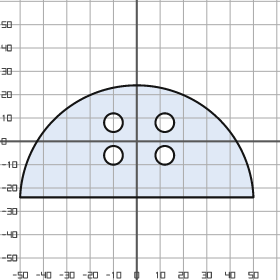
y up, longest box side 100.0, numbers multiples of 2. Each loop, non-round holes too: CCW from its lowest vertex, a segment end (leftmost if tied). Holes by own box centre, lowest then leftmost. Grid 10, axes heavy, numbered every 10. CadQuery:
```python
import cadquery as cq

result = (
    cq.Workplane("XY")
    .moveTo(-50.0, -24.0)
    .lineTo(50.0, -24.0)
    .threePointArc((0.0, 24.0), (-50.0, -24.0))
    .close()
    .moveTo(-10.0, -6.0)
    .circle(4.0)
    .moveTo(12.0, -6.0)
    .circle(4.0)
    .moveTo(-10.0, 8.0)
    .circle(4.0)
    .moveTo(12.0, 8.0)
    .circle(4.0)
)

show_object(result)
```